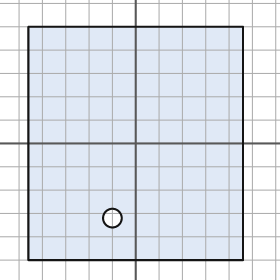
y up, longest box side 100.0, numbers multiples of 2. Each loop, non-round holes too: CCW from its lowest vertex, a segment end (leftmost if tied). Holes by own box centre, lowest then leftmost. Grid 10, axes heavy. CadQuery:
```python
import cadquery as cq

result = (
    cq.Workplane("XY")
    .moveTo(-46.0, -50.0)
    .lineTo(46.0, -50.0)
    .lineTo(46.0, 50.0)
    .lineTo(-46.0, 50.0)
    .close()
    .moveTo(-10.0, -32.0)
    .circle(4.0)
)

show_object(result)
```